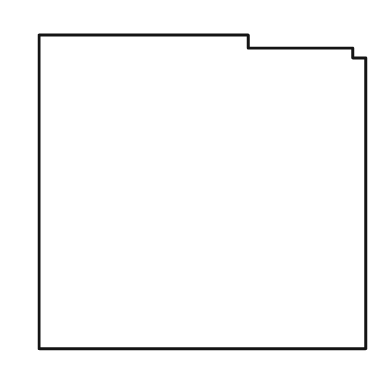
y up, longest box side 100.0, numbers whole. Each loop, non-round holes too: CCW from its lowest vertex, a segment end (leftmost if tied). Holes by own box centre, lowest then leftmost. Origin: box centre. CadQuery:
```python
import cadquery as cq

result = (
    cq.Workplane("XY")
    .moveTo(-50.0, -48.0)
    .lineTo(50.0, -48.0)
    .lineTo(50.0, 41.0)
    .lineTo(46.0, 41.0)
    .lineTo(46.0, 44.0)
    .lineTo(14.0, 44.0)
    .lineTo(14.0, 48.0)
    .lineTo(-50.0, 48.0)
    .close()
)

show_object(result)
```